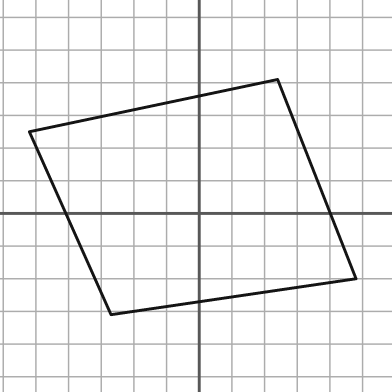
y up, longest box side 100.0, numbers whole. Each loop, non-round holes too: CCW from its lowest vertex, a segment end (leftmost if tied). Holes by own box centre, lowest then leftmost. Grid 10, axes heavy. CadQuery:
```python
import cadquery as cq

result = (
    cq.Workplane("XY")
    .moveTo(-27.0, -31.0)
    .lineTo(48.0, -20.0)
    .lineTo(24.0, 41.0)
    .lineTo(-52.0, 25.0)
    .close()
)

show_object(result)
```